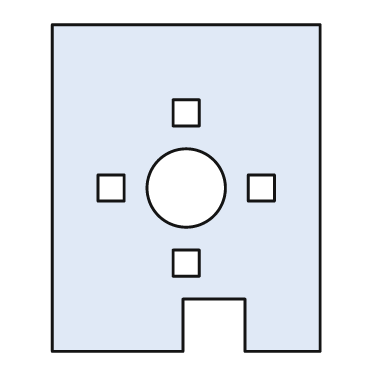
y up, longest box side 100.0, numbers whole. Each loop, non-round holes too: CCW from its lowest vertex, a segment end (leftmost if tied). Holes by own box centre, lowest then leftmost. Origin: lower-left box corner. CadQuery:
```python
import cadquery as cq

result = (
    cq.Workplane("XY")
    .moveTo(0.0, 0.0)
    .lineTo(40.0, 0.0)
    .lineTo(40.0, 16.0)
    .lineTo(59.0, 16.0)
    .lineTo(59.0, 0.0)
    .lineTo(82.0, 0.0)
    .lineTo(82.0, 100.0)
    .lineTo(0.0, 100.0)
    .close()
    .moveTo(37.0, 23.0)
    .lineTo(45.0, 23.0)
    .lineTo(45.0, 31.0)
    .lineTo(37.0, 31.0)
    .close()
    .moveTo(14.0, 46.0)
    .lineTo(22.0, 46.0)
    .lineTo(22.0, 54.0)
    .lineTo(14.0, 54.0)
    .close()
    .moveTo(41.0, 50.0)
    .circle(12.0)
    .moveTo(60.0, 46.0)
    .lineTo(68.0, 46.0)
    .lineTo(68.0, 54.0)
    .lineTo(60.0, 54.0)
    .close()
    .moveTo(37.0, 69.0)
    .lineTo(45.0, 69.0)
    .lineTo(45.0, 77.0)
    .lineTo(37.0, 77.0)
    .close()
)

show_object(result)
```